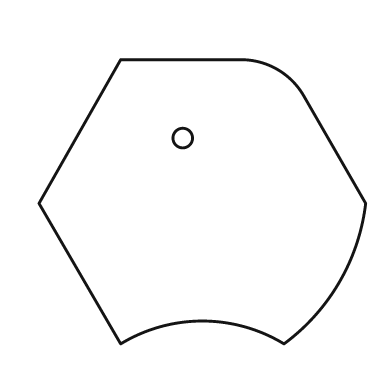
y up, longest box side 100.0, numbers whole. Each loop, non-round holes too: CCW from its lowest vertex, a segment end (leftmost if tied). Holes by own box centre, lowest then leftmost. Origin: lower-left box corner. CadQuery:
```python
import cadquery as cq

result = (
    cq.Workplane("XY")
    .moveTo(25.0, 0.0)
    .threePointArc((50.0, 7.0), (75.0, 0.0))
    .threePointArc((92.0, 19.0), (100.0, 43.0))
    .lineTo(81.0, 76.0)
    .threePointArc((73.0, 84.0), (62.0, 87.0))
    .lineTo(25.0, 87.0)
    .lineTo(0.0, 43.0)
    .close()
    .moveTo(44.0, 63.0)
    .circle(3.0)
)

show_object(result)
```